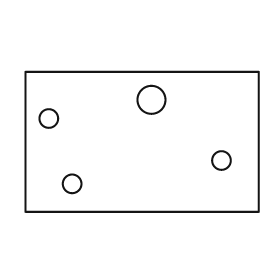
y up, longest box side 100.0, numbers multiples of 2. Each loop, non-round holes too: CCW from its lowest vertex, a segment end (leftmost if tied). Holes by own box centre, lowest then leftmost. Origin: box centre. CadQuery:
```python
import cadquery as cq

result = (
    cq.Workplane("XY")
    .moveTo(-50.0, -30.0)
    .lineTo(50.0, -30.0)
    .lineTo(50.0, 30.0)
    .lineTo(-50.0, 30.0)
    .close()
    .moveTo(-30.0, -18.0)
    .circle(4.0)
    .moveTo(34.0, -8.0)
    .circle(4.0)
    .moveTo(-40.0, 10.0)
    .circle(4.0)
    .moveTo(4.0, 18.0)
    .circle(6.0)
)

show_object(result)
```